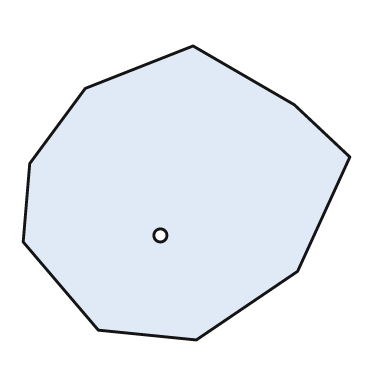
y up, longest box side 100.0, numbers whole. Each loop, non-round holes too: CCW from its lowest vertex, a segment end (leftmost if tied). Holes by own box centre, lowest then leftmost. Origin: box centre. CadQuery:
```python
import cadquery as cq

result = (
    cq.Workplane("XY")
    .moveTo(3.0, -45.0)
    .lineTo(34.0, -24.0)
    .lineTo(50.0, 11.0)
    .lineTo(33.0, 27.0)
    .lineTo(2.0, 45.0)
    .lineTo(-31.0, 32.0)
    .lineTo(-48.0, 9.0)
    .lineTo(-50.0, -15.0)
    .lineTo(-27.0, -42.0)
    .close()
    .moveTo(-8.0, -13.0)
    .circle(2.0)
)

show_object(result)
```